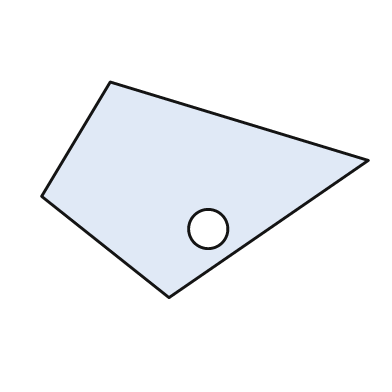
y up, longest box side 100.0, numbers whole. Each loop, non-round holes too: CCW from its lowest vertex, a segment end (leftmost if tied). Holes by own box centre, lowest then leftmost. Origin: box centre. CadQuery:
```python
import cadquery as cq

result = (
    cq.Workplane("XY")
    .moveTo(-11.0, -33.0)
    .lineTo(50.0, 9.0)
    .lineTo(-29.0, 33.0)
    .lineTo(-50.0, -2.0)
    .close()
    .moveTo(1.0, -12.0)
    .circle(6.0)
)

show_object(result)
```